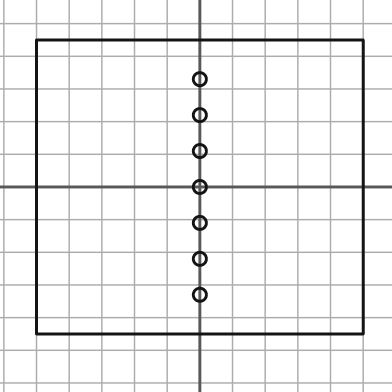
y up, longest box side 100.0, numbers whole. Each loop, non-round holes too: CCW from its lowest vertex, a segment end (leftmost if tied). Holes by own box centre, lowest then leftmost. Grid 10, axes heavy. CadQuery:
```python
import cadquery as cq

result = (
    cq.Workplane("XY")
    .moveTo(-50.0, -45.0)
    .lineTo(50.0, -45.0)
    .lineTo(50.0, 45.0)
    .lineTo(-50.0, 45.0)
    .close()
    .moveTo(0.0, -33.0)
    .circle(2.0)
    .moveTo(0.0, -22.0)
    .circle(2.0)
    .moveTo(0.0, -11.0)
    .circle(2.0)
    .moveTo(0.0, 0.0)
    .circle(2.0)
    .moveTo(0.0, 11.0)
    .circle(2.0)
    .moveTo(0.0, 22.0)
    .circle(2.0)
    .moveTo(0.0, 33.0)
    .circle(2.0)
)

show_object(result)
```